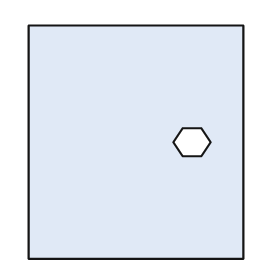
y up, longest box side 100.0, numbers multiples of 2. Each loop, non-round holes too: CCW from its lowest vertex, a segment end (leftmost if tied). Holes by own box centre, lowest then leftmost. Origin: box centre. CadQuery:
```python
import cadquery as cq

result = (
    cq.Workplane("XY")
    .moveTo(-46.0, -50.0)
    .lineTo(46.0, -50.0)
    .lineTo(46.0, 50.0)
    .lineTo(-46.0, 50.0)
    .close()
    .moveTo(20.0, -6.0)
    .lineTo(28.0, -6.0)
    .lineTo(32.0, 0.0)
    .lineTo(28.0, 6.0)
    .lineTo(20.0, 6.0)
    .lineTo(16.0, 0.0)
    .close()
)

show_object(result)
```